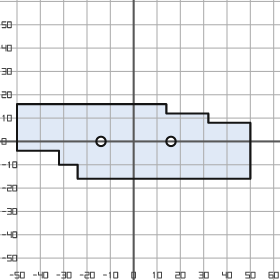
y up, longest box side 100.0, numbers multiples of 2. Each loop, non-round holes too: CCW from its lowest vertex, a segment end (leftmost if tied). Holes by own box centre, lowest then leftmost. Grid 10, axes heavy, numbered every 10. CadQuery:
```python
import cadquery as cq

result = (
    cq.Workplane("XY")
    .moveTo(-24.0, -16.0)
    .lineTo(50.0, -16.0)
    .lineTo(50.0, 8.0)
    .lineTo(32.0, 8.0)
    .lineTo(32.0, 12.0)
    .lineTo(14.0, 12.0)
    .lineTo(14.0, 16.0)
    .lineTo(-50.0, 16.0)
    .lineTo(-50.0, -4.0)
    .lineTo(-32.0, -4.0)
    .lineTo(-32.0, -10.0)
    .lineTo(-24.0, -10.0)
    .close()
    .moveTo(-14.0, 0.0)
    .circle(2.0)
    .moveTo(16.0, 0.0)
    .circle(2.0)
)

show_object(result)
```